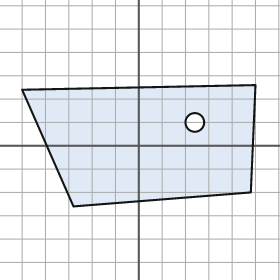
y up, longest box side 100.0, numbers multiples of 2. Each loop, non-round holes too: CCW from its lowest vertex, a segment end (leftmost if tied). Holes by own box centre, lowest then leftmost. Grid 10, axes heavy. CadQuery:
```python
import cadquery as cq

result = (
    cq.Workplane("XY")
    .moveTo(-28.0, -26.0)
    .lineTo(48.0, -20.0)
    .lineTo(50.0, 26.0)
    .lineTo(-50.0, 24.0)
    .close()
    .moveTo(24.0, 10.0)
    .circle(4.0)
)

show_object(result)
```